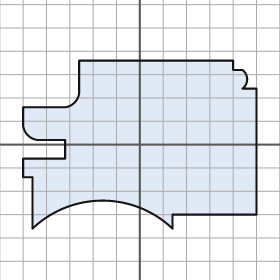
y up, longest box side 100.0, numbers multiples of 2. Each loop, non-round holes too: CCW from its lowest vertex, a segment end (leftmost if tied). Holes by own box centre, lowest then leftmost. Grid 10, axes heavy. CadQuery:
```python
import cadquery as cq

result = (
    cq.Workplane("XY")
    .moveTo(-46.0, -36.0)
    .threePointArc((-16.0, -24.0), (14.0, -36.0))
    .lineTo(14.0, -30.0)
    .lineTo(50.0, -30.0)
    .lineTo(50.0, 24.0)
    .lineTo(44.0, 24.0)
    .threePointArc((46.0, 28.0), (44.0, 32.0))
    .lineTo(40.0, 32.0)
    .lineTo(40.0, 36.0)
    .lineTo(-26.0, 36.0)
    .lineTo(-26.0, 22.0)
    .threePointArc((-28.0, 18.0), (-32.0, 16.0))
    .lineTo(-50.0, 16.0)
    .lineTo(-50.0, 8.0)
    .threePointArc((-48.0, 4.0), (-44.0, 2.0))
    .lineTo(-32.0, 2.0)
    .lineTo(-32.0, -6.0)
    .lineTo(-50.0, -6.0)
    .lineTo(-50.0, -14.0)
    .lineTo(-46.0, -14.0)
    .close()
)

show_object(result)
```